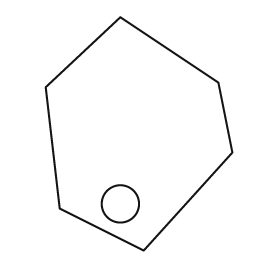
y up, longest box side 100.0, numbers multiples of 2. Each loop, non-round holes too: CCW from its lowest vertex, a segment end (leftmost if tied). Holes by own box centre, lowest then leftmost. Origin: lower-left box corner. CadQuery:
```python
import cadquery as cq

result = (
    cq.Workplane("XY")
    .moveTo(42.0, 0.0)
    .lineTo(80.0, 42.0)
    .lineTo(74.0, 72.0)
    .lineTo(32.0, 100.0)
    .lineTo(0.0, 70.0)
    .lineTo(6.0, 18.0)
    .close()
    .moveTo(32.0, 20.0)
    .circle(8.0)
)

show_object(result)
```